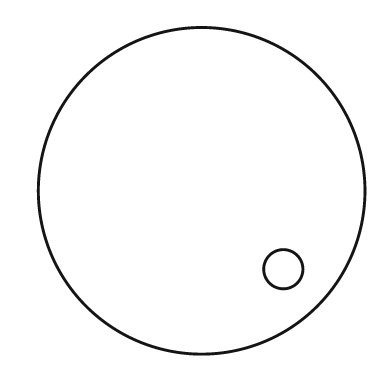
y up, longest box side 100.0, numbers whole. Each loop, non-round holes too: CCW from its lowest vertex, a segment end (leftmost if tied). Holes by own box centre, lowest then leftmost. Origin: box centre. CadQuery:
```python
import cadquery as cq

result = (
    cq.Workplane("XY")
    .moveTo(0.0, 0.0)
    .circle(50.0)
    .moveTo(25.0, -24.0)
    .circle(6.0)
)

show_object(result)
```